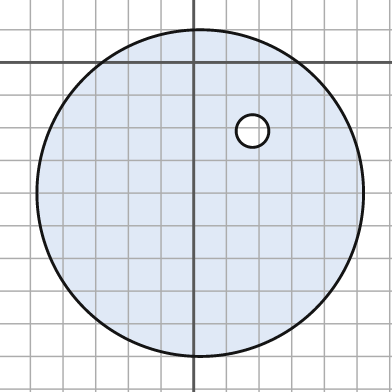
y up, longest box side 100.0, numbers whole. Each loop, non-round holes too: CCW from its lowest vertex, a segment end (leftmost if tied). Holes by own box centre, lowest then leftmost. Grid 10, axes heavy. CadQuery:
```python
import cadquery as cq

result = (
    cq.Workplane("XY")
    .moveTo(2.0, -40.0)
    .circle(50.0)
    .moveTo(18.0, -21.0)
    .circle(5.0)
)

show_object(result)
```